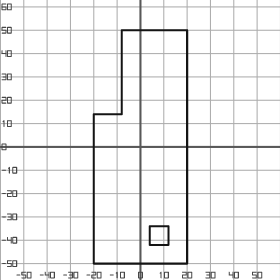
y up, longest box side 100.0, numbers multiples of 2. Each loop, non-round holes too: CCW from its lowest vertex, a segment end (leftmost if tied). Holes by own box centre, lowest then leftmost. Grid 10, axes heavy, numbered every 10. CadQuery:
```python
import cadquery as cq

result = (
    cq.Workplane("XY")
    .moveTo(-20.0, -50.0)
    .lineTo(20.0, -50.0)
    .lineTo(20.0, 50.0)
    .lineTo(-8.0, 50.0)
    .lineTo(-8.0, 14.0)
    .lineTo(-20.0, 14.0)
    .close()
    .moveTo(4.0, -42.0)
    .lineTo(12.0, -42.0)
    .lineTo(12.0, -34.0)
    .lineTo(4.0, -34.0)
    .close()
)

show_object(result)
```